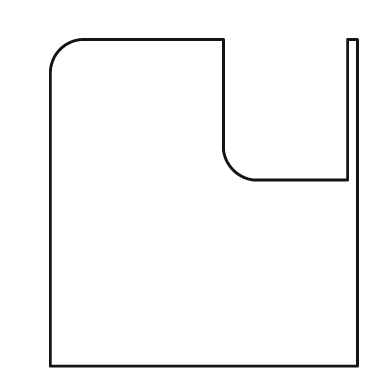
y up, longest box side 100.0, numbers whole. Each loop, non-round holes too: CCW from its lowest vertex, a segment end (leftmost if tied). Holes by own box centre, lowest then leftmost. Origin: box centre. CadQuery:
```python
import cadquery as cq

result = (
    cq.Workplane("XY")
    .moveTo(-47.0, -50.0)
    .lineTo(47.0, -50.0)
    .lineTo(47.0, 50.0)
    .lineTo(44.0, 50.0)
    .lineTo(44.0, 7.0)
    .lineTo(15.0, 7.0)
    .threePointArc((9.0, 10.0), (6.0, 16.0))
    .lineTo(6.0, 50.0)
    .lineTo(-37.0, 50.0)
    .threePointArc((-44.0, 47.0), (-47.0, 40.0))
    .close()
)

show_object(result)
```